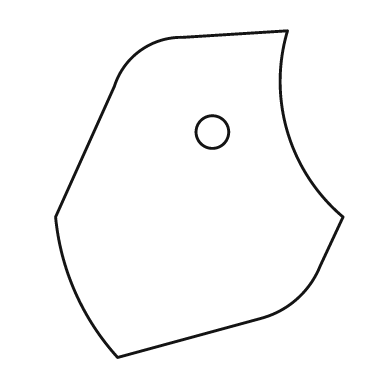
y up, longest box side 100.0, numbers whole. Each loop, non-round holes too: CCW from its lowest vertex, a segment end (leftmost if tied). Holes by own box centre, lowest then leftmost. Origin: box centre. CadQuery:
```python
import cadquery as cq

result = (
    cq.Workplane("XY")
    .moveTo(-25.0, -50.0)
    .lineTo(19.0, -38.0)
    .threePointArc((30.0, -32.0), (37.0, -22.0))
    .lineTo(44.0, -7.0)
    .threePointArc((27.0, 19.0), (27.0, 50.0))
    .lineTo(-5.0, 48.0)
    .threePointArc((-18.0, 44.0), (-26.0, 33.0))
    .lineTo(-44.0, -7.0)
    .threePointArc((-38.0, -30.0), (-25.0, -50.0))
    .close()
    .moveTo(4.0, 19.0)
    .circle(5.0)
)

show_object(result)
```